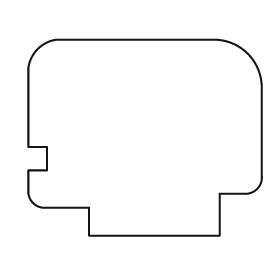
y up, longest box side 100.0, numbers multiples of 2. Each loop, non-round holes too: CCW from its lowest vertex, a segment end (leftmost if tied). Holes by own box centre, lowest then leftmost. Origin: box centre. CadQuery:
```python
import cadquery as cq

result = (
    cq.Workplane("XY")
    .moveTo(-24.0, -42.0)
    .lineTo(32.0, -42.0)
    .lineTo(32.0, -24.0)
    .lineTo(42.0, -24.0)
    .threePointArc((48.0, -22.0), (50.0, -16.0))
    .lineTo(50.0, 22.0)
    .threePointArc((44.0, 36.0), (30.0, 42.0))
    .lineTo(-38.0, 42.0)
    .threePointArc((-46.0, 38.0), (-50.0, 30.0))
    .lineTo(-50.0, -4.0)
    .lineTo(-42.0, -4.0)
    .lineTo(-42.0, -14.0)
    .lineTo(-50.0, -14.0)
    .lineTo(-50.0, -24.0)
    .threePointArc((-48.0, -28.0), (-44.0, -30.0))
    .lineTo(-24.0, -30.0)
    .close()
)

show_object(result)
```